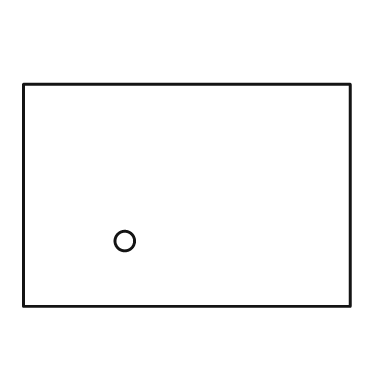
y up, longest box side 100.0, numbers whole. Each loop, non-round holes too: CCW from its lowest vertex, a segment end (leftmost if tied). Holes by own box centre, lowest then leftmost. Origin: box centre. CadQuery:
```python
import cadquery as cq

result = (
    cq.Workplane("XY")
    .moveTo(-50.0, -34.0)
    .lineTo(50.0, -34.0)
    .lineTo(50.0, 34.0)
    .lineTo(-50.0, 34.0)
    .close()
    .moveTo(-19.0, -14.0)
    .circle(3.0)
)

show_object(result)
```